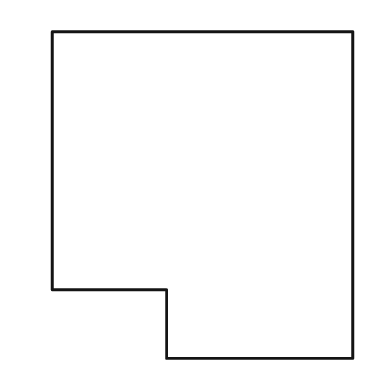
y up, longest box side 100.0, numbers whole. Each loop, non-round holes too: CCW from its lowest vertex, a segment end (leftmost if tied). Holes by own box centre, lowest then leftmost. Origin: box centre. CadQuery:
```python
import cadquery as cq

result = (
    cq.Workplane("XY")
    .moveTo(-11.0, -50.0)
    .lineTo(46.0, -50.0)
    .lineTo(46.0, 50.0)
    .lineTo(-46.0, 50.0)
    .lineTo(-46.0, -29.0)
    .lineTo(-11.0, -29.0)
    .close()
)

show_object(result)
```